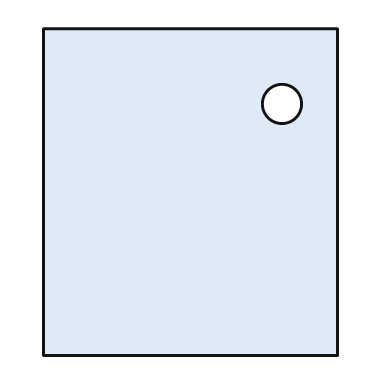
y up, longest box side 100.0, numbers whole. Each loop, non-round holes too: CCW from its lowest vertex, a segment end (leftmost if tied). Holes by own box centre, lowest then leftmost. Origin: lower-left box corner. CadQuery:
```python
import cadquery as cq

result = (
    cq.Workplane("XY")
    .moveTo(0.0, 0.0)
    .lineTo(90.0, 0.0)
    .lineTo(90.0, 100.0)
    .lineTo(0.0, 100.0)
    .close()
    .moveTo(73.0, 77.0)
    .circle(6.0)
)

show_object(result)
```